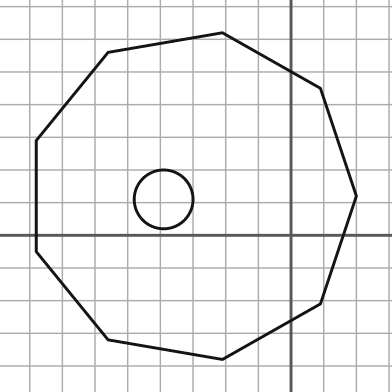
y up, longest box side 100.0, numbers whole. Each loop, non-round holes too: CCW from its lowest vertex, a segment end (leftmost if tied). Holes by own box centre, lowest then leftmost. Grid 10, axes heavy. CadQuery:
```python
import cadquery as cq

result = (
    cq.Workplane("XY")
    .moveTo(-21.0, -38.0)
    .lineTo(9.0, -21.0)
    .lineTo(20.0, 12.0)
    .lineTo(9.0, 45.0)
    .lineTo(-21.0, 62.0)
    .lineTo(-56.0, 56.0)
    .lineTo(-78.0, 29.0)
    .lineTo(-78.0, -5.0)
    .lineTo(-56.0, -32.0)
    .close()
    .moveTo(-39.0, 11.0)
    .circle(9.0)
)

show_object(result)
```